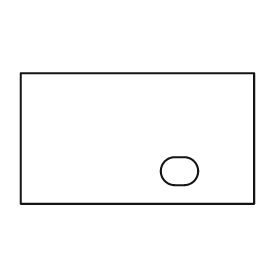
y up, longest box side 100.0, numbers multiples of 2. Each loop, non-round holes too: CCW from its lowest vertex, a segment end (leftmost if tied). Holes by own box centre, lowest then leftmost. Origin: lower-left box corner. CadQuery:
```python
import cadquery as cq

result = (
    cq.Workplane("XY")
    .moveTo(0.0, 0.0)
    .lineTo(100.0, 0.0)
    .lineTo(100.0, 56.0)
    .lineTo(0.0, 56.0)
    .close()
    .moveTo(66.0, 8.0)
    .lineTo(70.0, 8.0)
    .threePointArc((76.0, 14.0), (70.0, 20.0))
    .lineTo(66.0, 20.0)
    .threePointArc((60.0, 14.0), (66.0, 8.0))
    .close()
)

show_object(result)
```